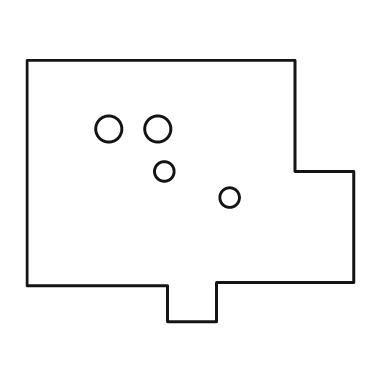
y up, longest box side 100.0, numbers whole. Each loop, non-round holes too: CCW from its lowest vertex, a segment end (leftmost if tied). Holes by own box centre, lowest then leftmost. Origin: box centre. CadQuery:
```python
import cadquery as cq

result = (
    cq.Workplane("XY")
    .moveTo(-7.0, -40.0)
    .lineTo(8.0, -40.0)
    .lineTo(8.0, -28.0)
    .lineTo(50.0, -28.0)
    .lineTo(50.0, 6.0)
    .lineTo(32.0, 6.0)
    .lineTo(32.0, 40.0)
    .lineTo(-50.0, 40.0)
    .lineTo(-50.0, -29.0)
    .lineTo(-7.0, -29.0)
    .close()
    .moveTo(12.0, -2.0)
    .circle(3.0)
    .moveTo(-8.0, 6.0)
    .circle(3.0)
    .moveTo(-25.0, 19.0)
    .circle(4.0)
    .moveTo(-10.0, 19.0)
    .circle(4.0)
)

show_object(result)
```